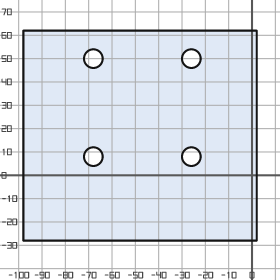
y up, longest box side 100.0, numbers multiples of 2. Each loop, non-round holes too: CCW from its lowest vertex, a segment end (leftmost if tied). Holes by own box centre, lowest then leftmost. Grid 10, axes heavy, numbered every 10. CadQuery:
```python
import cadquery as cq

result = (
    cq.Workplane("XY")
    .moveTo(-98.0, -28.0)
    .lineTo(2.0, -28.0)
    .lineTo(2.0, 62.0)
    .lineTo(-98.0, 62.0)
    .close()
    .moveTo(-68.0, 8.0)
    .circle(4.0)
    .moveTo(-26.0, 8.0)
    .circle(4.0)
    .moveTo(-68.0, 50.0)
    .circle(4.0)
    .moveTo(-26.0, 50.0)
    .circle(4.0)
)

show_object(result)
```